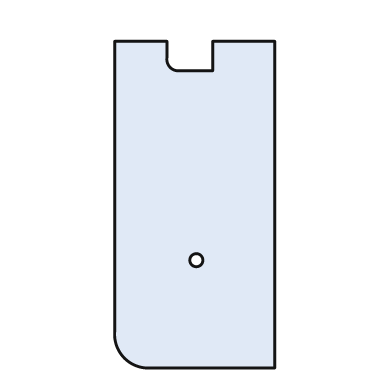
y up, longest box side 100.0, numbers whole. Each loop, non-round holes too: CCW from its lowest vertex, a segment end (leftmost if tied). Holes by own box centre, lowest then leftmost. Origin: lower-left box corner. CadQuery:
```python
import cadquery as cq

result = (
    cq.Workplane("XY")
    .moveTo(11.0, 0.0)
    .lineTo(49.0, 0.0)
    .lineTo(49.0, 100.0)
    .lineTo(30.0, 100.0)
    .lineTo(30.0, 91.0)
    .lineTo(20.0, 91.0)
    .threePointArc((17.0, 92.0), (16.0, 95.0))
    .lineTo(16.0, 100.0)
    .lineTo(0.0, 100.0)
    .lineTo(0.0, 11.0)
    .threePointArc((3.0, 3.0), (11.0, 0.0))
    .close()
    .moveTo(25.0, 33.0)
    .circle(2.0)
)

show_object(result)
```